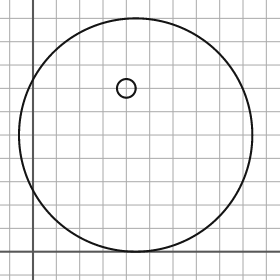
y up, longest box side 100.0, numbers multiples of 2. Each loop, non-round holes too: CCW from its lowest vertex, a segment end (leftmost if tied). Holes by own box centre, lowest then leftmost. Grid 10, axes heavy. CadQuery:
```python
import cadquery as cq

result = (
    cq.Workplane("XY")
    .moveTo(44.0, 50.0)
    .circle(50.0)
    .moveTo(40.0, 70.0)
    .circle(4.0)
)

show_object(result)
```